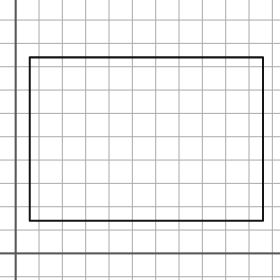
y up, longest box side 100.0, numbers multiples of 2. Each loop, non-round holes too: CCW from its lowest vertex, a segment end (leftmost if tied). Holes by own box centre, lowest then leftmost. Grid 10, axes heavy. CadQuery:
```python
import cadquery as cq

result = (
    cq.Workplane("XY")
    .moveTo(6.0, 14.0)
    .lineTo(106.0, 14.0)
    .lineTo(106.0, 84.0)
    .lineTo(6.0, 84.0)
    .close()
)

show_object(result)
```